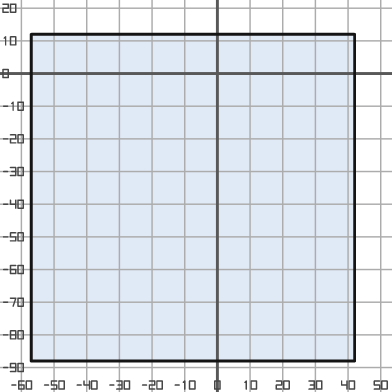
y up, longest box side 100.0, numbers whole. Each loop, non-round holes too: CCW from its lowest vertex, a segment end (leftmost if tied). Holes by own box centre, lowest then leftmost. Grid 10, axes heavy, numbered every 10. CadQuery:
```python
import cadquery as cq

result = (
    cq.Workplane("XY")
    .moveTo(-57.0, -88.0)
    .lineTo(42.0, -88.0)
    .lineTo(42.0, 12.0)
    .lineTo(-57.0, 12.0)
    .close()
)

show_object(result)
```